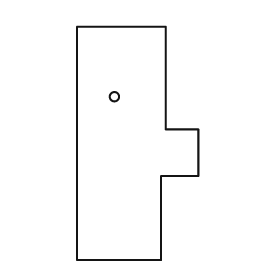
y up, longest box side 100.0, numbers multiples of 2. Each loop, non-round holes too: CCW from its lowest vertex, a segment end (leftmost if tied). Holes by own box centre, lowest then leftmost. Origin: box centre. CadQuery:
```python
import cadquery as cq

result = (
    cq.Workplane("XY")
    .moveTo(-26.0, -50.0)
    .lineTo(10.0, -50.0)
    .lineTo(10.0, -14.0)
    .lineTo(26.0, -14.0)
    .lineTo(26.0, 6.0)
    .lineTo(12.0, 6.0)
    .lineTo(12.0, 50.0)
    .lineTo(-26.0, 50.0)
    .close()
    .moveTo(-10.0, 20.0)
    .circle(2.0)
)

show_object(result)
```